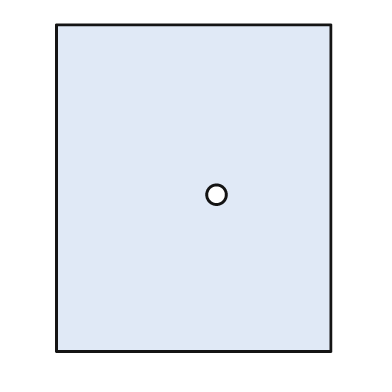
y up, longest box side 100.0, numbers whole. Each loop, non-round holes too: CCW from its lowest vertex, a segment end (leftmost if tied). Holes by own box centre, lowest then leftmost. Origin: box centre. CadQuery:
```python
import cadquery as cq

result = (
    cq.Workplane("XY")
    .moveTo(-42.0, -50.0)
    .lineTo(42.0, -50.0)
    .lineTo(42.0, 50.0)
    .lineTo(-42.0, 50.0)
    .close()
    .moveTo(7.0, -2.0)
    .circle(3.0)
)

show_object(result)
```